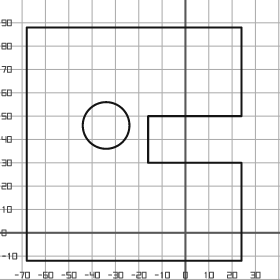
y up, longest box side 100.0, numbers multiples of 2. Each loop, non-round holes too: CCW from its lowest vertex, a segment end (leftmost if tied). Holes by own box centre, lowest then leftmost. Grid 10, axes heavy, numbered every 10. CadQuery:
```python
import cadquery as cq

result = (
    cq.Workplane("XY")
    .moveTo(-68.0, -12.0)
    .lineTo(24.0, -12.0)
    .lineTo(24.0, 30.0)
    .lineTo(-16.0, 30.0)
    .lineTo(-16.0, 50.0)
    .lineTo(24.0, 50.0)
    .lineTo(24.0, 88.0)
    .lineTo(-68.0, 88.0)
    .close()
    .moveTo(-34.0, 46.0)
    .circle(10.0)
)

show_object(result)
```